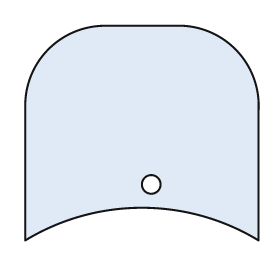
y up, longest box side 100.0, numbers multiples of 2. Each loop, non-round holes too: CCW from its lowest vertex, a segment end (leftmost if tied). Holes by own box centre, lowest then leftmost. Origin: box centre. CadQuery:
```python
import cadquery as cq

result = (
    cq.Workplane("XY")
    .moveTo(-50.0, -46.0)
    .threePointArc((0.0, -32.0), (50.0, -46.0))
    .lineTo(50.0, 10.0)
    .threePointArc((40.0, 36.0), (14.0, 46.0))
    .lineTo(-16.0, 46.0)
    .threePointArc((-40.0, 36.0), (-50.0, 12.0))
    .close()
    .moveTo(4.0, -22.0)
    .circle(4.0)
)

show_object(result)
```